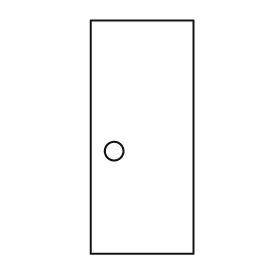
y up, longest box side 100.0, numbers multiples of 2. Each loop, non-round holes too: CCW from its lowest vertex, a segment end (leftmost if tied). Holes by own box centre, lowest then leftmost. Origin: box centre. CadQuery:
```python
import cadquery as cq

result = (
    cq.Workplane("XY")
    .moveTo(-22.0, -50.0)
    .lineTo(22.0, -50.0)
    .lineTo(22.0, 50.0)
    .lineTo(-22.0, 50.0)
    .close()
    .moveTo(-12.0, -6.0)
    .circle(4.0)
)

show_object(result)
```